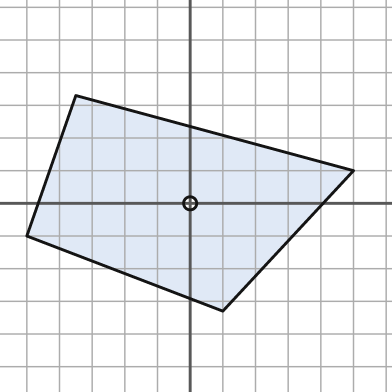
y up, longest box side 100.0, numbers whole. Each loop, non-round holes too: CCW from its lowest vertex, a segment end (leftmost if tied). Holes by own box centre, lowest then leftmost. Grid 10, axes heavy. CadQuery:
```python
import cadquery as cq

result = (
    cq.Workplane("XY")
    .moveTo(10.0, -33.0)
    .lineTo(50.0, 10.0)
    .lineTo(-35.0, 33.0)
    .lineTo(-50.0, -10.0)
    .close()
    .moveTo(0.0, 0.0)
    .circle(2.0)
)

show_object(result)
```